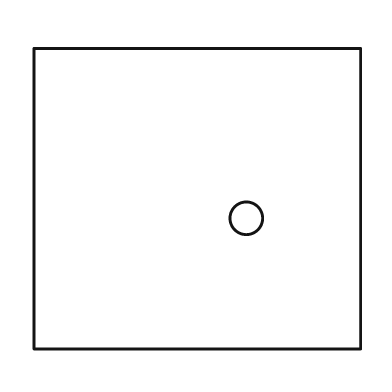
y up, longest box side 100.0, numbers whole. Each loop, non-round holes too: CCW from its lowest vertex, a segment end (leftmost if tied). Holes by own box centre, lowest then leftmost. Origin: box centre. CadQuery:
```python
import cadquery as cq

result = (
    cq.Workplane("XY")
    .moveTo(-50.0, -46.0)
    .lineTo(50.0, -46.0)
    .lineTo(50.0, 46.0)
    .lineTo(-50.0, 46.0)
    .close()
    .moveTo(15.0, -6.0)
    .circle(5.0)
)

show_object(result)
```